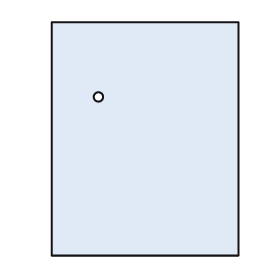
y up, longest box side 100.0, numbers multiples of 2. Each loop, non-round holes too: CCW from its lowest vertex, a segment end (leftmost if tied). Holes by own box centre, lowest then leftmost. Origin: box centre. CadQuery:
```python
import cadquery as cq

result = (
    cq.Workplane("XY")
    .moveTo(-40.0, -50.0)
    .lineTo(40.0, -50.0)
    .lineTo(40.0, 50.0)
    .lineTo(-40.0, 50.0)
    .close()
    .moveTo(-20.0, 18.0)
    .circle(2.0)
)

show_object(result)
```